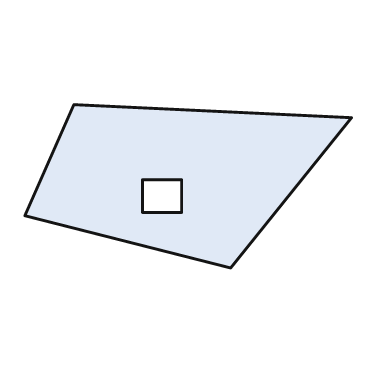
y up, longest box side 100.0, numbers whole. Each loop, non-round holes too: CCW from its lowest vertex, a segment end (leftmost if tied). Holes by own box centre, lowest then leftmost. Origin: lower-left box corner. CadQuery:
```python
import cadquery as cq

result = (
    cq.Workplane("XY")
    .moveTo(63.0, 0.0)
    .lineTo(100.0, 46.0)
    .lineTo(15.0, 50.0)
    .lineTo(0.0, 16.0)
    .close()
    .moveTo(36.0, 17.0)
    .lineTo(48.0, 17.0)
    .lineTo(48.0, 27.0)
    .lineTo(36.0, 27.0)
    .close()
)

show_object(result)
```